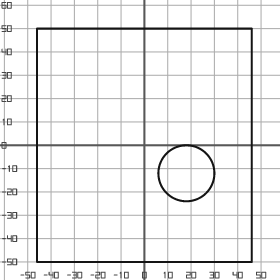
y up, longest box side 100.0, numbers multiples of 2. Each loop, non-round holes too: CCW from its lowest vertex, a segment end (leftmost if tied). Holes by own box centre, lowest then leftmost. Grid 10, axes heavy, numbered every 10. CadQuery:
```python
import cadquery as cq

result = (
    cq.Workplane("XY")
    .moveTo(-46.0, -50.0)
    .lineTo(46.0, -50.0)
    .lineTo(46.0, 50.0)
    .lineTo(-46.0, 50.0)
    .close()
    .moveTo(18.0, -12.0)
    .circle(12.0)
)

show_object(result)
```